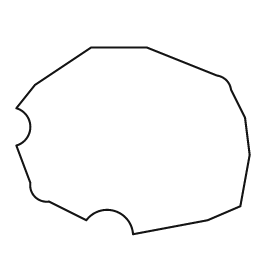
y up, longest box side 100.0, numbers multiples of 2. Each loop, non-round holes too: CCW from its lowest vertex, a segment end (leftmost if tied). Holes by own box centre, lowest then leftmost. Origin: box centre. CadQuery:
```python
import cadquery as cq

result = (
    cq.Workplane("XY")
    .moveTo(0.0, -40.0)
    .lineTo(32.0, -34.0)
    .lineTo(46.0, -28.0)
    .lineTo(50.0, -6.0)
    .lineTo(48.0, 10.0)
    .lineTo(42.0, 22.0)
    .threePointArc((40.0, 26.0), (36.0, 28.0))
    .lineTo(6.0, 40.0)
    .lineTo(-18.0, 40.0)
    .lineTo(-42.0, 24.0)
    .lineTo(-50.0, 14.0)
    .threePointArc((-44.0, 6.0), (-50.0, -2.0))
    .lineTo(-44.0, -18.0)
    .threePointArc((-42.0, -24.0), (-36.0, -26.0))
    .lineTo(-20.0, -34.0)
    .threePointArc((-8.0, -30.0), (0.0, -40.0))
    .close()
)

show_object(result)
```